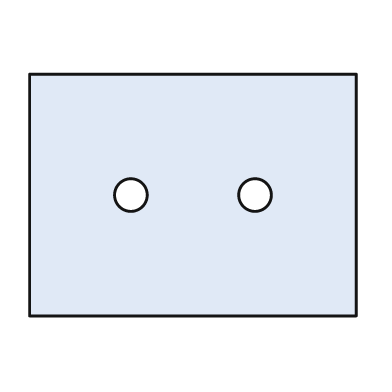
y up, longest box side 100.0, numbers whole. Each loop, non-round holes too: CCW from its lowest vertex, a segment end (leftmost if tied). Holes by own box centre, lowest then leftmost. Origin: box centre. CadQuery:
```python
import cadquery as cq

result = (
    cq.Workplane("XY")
    .moveTo(-50.0, -37.0)
    .lineTo(50.0, -37.0)
    .lineTo(50.0, 37.0)
    .lineTo(-50.0, 37.0)
    .close()
    .moveTo(-19.0, 0.0)
    .circle(5.0)
    .moveTo(19.0, 0.0)
    .circle(5.0)
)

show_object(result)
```